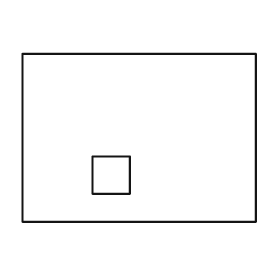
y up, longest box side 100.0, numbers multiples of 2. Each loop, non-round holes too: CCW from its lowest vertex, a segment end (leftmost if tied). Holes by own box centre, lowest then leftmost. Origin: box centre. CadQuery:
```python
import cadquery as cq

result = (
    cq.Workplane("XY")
    .moveTo(-50.0, -36.0)
    .lineTo(50.0, -36.0)
    .lineTo(50.0, 36.0)
    .lineTo(-50.0, 36.0)
    .close()
    .moveTo(-20.0, -24.0)
    .lineTo(-4.0, -24.0)
    .lineTo(-4.0, -8.0)
    .lineTo(-20.0, -8.0)
    .close()
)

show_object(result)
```